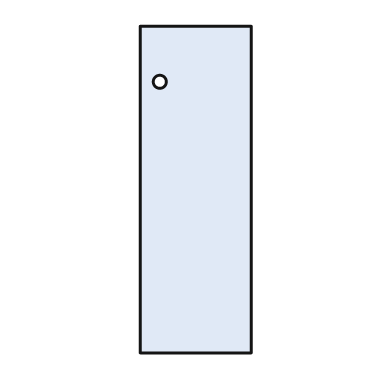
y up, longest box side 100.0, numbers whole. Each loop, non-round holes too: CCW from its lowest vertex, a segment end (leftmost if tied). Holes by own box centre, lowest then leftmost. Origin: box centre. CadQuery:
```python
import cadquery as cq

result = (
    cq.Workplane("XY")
    .moveTo(-17.0, -50.0)
    .lineTo(17.0, -50.0)
    .lineTo(17.0, 50.0)
    .lineTo(-17.0, 50.0)
    .close()
    .moveTo(-11.0, 33.0)
    .circle(2.0)
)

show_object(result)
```